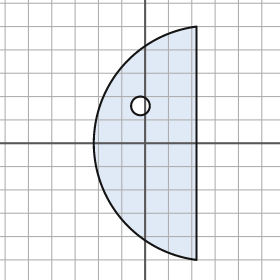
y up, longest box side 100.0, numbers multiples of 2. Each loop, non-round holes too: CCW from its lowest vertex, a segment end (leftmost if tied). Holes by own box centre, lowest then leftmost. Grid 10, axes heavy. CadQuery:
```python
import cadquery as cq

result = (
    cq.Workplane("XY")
    .moveTo(22.0, -50.0)
    .lineTo(22.0, 50.0)
    .threePointArc((-22.0, 0.0), (22.0, -50.0))
    .close()
    .moveTo(-2.0, 16.0)
    .circle(4.0)
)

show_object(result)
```